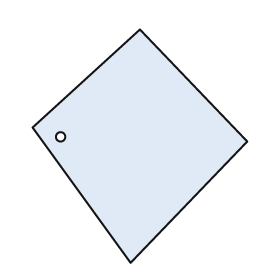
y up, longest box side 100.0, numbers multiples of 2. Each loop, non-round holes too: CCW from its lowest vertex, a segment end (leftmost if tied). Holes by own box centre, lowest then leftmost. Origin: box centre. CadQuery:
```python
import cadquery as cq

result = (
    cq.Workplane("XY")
    .moveTo(-4.0, -50.0)
    .lineTo(46.0, 2.0)
    .lineTo(0.0, 50.0)
    .lineTo(-46.0, 8.0)
    .close()
    .moveTo(-34.0, 4.0)
    .circle(2.0)
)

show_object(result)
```